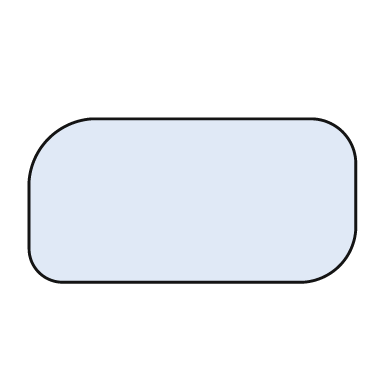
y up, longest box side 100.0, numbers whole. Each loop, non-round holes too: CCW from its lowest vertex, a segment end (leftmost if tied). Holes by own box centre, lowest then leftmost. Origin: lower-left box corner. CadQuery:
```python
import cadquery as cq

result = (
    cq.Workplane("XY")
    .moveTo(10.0, 0.0)
    .lineTo(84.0, 0.0)
    .threePointArc((95.0, 5.0), (100.0, 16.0))
    .lineTo(100.0, 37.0)
    .threePointArc((96.0, 46.0), (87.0, 50.0))
    .lineTo(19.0, 50.0)
    .threePointArc((6.0, 44.0), (0.0, 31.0))
    .lineTo(0.0, 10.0)
    .threePointArc((3.0, 3.0), (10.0, 0.0))
    .close()
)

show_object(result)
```